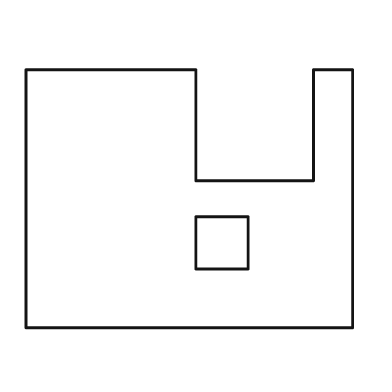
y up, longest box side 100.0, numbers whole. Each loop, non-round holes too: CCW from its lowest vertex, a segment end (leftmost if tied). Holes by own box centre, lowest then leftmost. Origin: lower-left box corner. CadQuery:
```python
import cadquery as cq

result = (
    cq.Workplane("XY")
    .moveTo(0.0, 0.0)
    .lineTo(100.0, 0.0)
    .lineTo(100.0, 79.0)
    .lineTo(88.0, 79.0)
    .lineTo(88.0, 45.0)
    .lineTo(52.0, 45.0)
    .lineTo(52.0, 79.0)
    .lineTo(0.0, 79.0)
    .close()
    .moveTo(52.0, 18.0)
    .lineTo(68.0, 18.0)
    .lineTo(68.0, 34.0)
    .lineTo(52.0, 34.0)
    .close()
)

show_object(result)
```